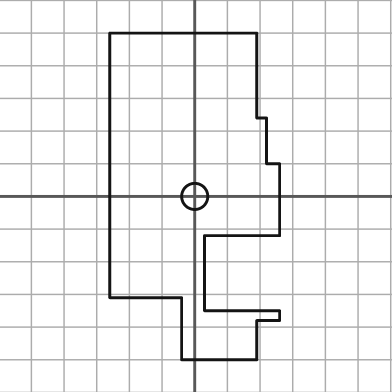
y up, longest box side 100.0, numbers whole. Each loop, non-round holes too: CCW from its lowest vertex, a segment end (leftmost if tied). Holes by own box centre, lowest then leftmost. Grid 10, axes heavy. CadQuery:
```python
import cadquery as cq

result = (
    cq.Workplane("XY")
    .moveTo(-4.0, -50.0)
    .lineTo(19.0, -50.0)
    .lineTo(19.0, -38.0)
    .lineTo(26.0, -38.0)
    .lineTo(26.0, -35.0)
    .lineTo(3.0, -35.0)
    .lineTo(3.0, -12.0)
    .lineTo(26.0, -12.0)
    .lineTo(26.0, 10.0)
    .lineTo(22.0, 10.0)
    .lineTo(22.0, 24.0)
    .lineTo(19.0, 24.0)
    .lineTo(19.0, 50.0)
    .lineTo(-26.0, 50.0)
    .lineTo(-26.0, -31.0)
    .lineTo(-4.0, -31.0)
    .close()
    .moveTo(0.0, 0.0)
    .circle(4.0)
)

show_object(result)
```